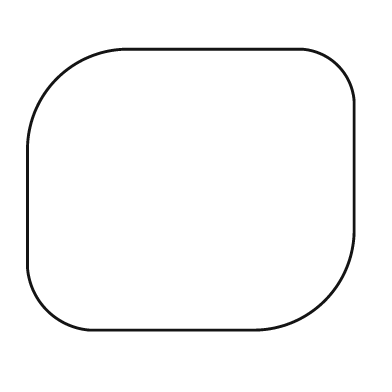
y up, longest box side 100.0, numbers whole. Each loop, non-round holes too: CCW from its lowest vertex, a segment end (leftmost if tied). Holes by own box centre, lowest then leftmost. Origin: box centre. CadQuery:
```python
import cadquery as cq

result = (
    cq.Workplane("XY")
    .moveTo(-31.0, -43.0)
    .lineTo(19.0, -43.0)
    .threePointArc((41.0, -34.0), (50.0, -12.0))
    .lineTo(50.0, 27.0)
    .threePointArc((45.0, 38.0), (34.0, 43.0))
    .lineTo(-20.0, 43.0)
    .threePointArc((-41.0, 34.0), (-50.0, 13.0))
    .lineTo(-50.0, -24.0)
    .threePointArc((-44.0, -37.0), (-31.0, -43.0))
    .close()
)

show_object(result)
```